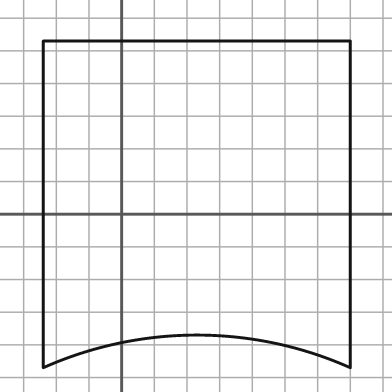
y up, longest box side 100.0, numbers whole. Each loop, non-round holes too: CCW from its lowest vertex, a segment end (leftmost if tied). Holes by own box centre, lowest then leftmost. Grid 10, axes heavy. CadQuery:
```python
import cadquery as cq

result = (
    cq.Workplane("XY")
    .moveTo(-24.0, -47.0)
    .threePointArc((23.0, -37.0), (70.0, -47.0))
    .lineTo(70.0, 53.0)
    .lineTo(-24.0, 53.0)
    .close()
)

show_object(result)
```